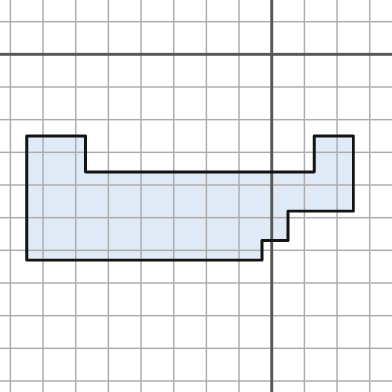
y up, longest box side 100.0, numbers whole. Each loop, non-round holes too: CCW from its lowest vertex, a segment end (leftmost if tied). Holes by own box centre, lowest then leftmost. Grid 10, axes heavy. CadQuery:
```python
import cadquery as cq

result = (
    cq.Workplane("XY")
    .moveTo(-75.0, -63.0)
    .lineTo(-3.0, -63.0)
    .lineTo(-3.0, -57.0)
    .lineTo(5.0, -57.0)
    .lineTo(5.0, -48.0)
    .lineTo(25.0, -48.0)
    .lineTo(25.0, -25.0)
    .lineTo(13.0, -25.0)
    .lineTo(13.0, -36.0)
    .lineTo(-57.0, -36.0)
    .lineTo(-57.0, -25.0)
    .lineTo(-75.0, -25.0)
    .close()
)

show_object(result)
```